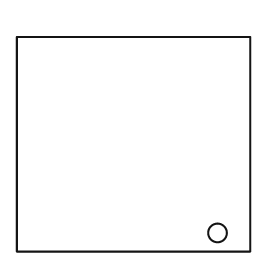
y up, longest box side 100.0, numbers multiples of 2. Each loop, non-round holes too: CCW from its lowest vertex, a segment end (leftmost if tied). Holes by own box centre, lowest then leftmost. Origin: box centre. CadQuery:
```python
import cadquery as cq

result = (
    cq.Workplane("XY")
    .moveTo(-50.0, -46.0)
    .lineTo(50.0, -46.0)
    .lineTo(50.0, 46.0)
    .lineTo(-50.0, 46.0)
    .close()
    .moveTo(36.0, -38.0)
    .circle(4.0)
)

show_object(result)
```